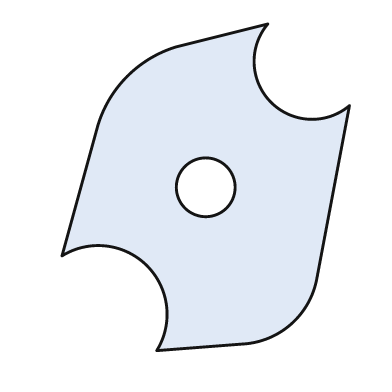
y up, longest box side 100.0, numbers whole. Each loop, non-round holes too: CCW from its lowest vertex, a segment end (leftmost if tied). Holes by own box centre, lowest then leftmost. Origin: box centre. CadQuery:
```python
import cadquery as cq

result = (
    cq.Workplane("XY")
    .moveTo(-15.0, -50.0)
    .lineTo(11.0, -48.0)
    .threePointArc((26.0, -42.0), (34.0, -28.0))
    .lineTo(44.0, 25.0)
    .threePointArc((20.0, 26.0), (19.0, 50.0))
    .lineTo(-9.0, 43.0)
    .threePointArc((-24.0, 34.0), (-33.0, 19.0))
    .lineTo(-44.0, -21.0)
    .threePointArc((-18.0, -24.0), (-15.0, -50.0))
    .close()
    .moveTo(0.0, 0.0)
    .circle(9.0)
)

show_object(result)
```